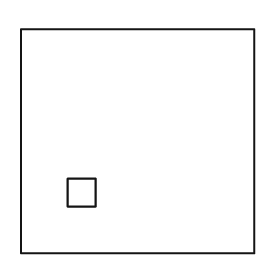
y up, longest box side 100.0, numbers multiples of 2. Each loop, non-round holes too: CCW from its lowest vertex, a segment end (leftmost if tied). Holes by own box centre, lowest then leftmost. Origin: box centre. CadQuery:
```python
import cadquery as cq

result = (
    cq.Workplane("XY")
    .moveTo(-50.0, -48.0)
    .lineTo(50.0, -48.0)
    .lineTo(50.0, 48.0)
    .lineTo(-50.0, 48.0)
    .close()
    .moveTo(-30.0, -28.0)
    .lineTo(-18.0, -28.0)
    .lineTo(-18.0, -16.0)
    .lineTo(-30.0, -16.0)
    .close()
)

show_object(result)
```